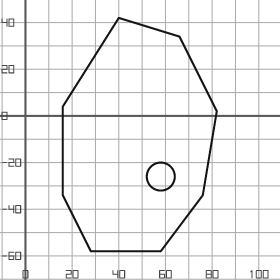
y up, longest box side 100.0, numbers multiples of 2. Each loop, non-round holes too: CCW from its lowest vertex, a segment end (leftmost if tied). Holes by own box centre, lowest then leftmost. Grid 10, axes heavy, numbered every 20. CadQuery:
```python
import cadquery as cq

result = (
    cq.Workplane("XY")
    .moveTo(28.0, -58.0)
    .lineTo(58.0, -58.0)
    .lineTo(76.0, -34.0)
    .lineTo(82.0, 2.0)
    .lineTo(66.0, 34.0)
    .lineTo(40.0, 42.0)
    .lineTo(16.0, 4.0)
    .lineTo(16.0, -34.0)
    .close()
    .moveTo(58.0, -26.0)
    .circle(6.0)
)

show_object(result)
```